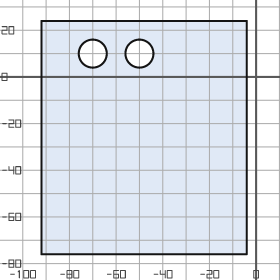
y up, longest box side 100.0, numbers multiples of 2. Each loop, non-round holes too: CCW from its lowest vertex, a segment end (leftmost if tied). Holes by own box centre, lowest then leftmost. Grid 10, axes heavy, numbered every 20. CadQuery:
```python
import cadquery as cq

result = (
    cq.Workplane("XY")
    .moveTo(-92.0, -76.0)
    .lineTo(-4.0, -76.0)
    .lineTo(-4.0, 24.0)
    .lineTo(-92.0, 24.0)
    .close()
    .moveTo(-70.0, 10.0)
    .circle(6.0)
    .moveTo(-50.0, 10.0)
    .circle(6.0)
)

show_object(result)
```